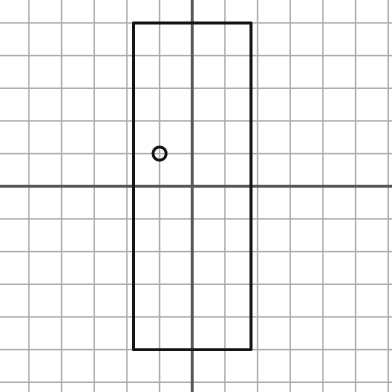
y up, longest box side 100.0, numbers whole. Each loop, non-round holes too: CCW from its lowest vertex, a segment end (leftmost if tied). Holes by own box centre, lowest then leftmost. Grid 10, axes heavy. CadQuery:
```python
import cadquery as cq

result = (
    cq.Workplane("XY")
    .moveTo(-18.0, -50.0)
    .lineTo(18.0, -50.0)
    .lineTo(18.0, 50.0)
    .lineTo(-18.0, 50.0)
    .close()
    .moveTo(-10.0, 10.0)
    .circle(2.0)
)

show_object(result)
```